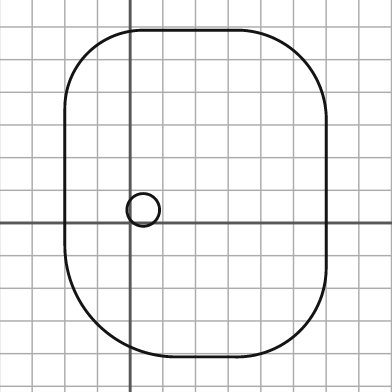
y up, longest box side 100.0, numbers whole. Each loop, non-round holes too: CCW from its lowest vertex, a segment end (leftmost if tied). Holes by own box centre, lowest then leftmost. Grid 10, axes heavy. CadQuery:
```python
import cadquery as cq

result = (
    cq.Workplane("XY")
    .moveTo(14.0, -41.0)
    .lineTo(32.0, -41.0)
    .threePointArc((52.0, -33.0), (60.0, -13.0))
    .lineTo(60.0, 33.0)
    .threePointArc((52.0, 51.0), (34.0, 59.0))
    .lineTo(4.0, 59.0)
    .threePointArc((-13.0, 52.0), (-20.0, 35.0))
    .lineTo(-20.0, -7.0)
    .threePointArc((-10.0, -31.0), (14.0, -41.0))
    .close()
    .moveTo(4.0, 4.0)
    .circle(5.0)
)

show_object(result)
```